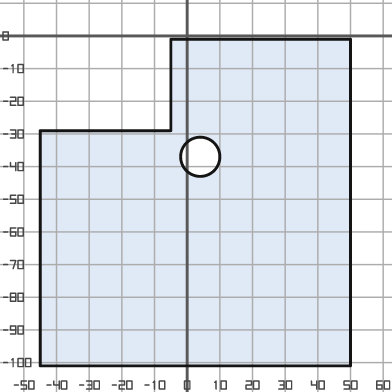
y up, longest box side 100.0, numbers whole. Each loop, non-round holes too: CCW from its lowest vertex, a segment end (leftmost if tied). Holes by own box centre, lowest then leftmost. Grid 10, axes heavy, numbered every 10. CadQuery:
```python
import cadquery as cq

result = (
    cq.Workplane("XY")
    .moveTo(-45.0, -101.0)
    .lineTo(50.0, -101.0)
    .lineTo(50.0, -1.0)
    .lineTo(-5.0, -1.0)
    .lineTo(-5.0, -29.0)
    .lineTo(-45.0, -29.0)
    .close()
    .moveTo(4.0, -37.0)
    .circle(6.0)
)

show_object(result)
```